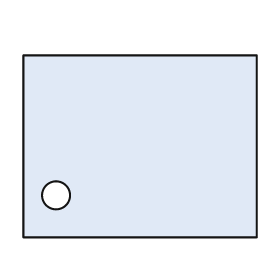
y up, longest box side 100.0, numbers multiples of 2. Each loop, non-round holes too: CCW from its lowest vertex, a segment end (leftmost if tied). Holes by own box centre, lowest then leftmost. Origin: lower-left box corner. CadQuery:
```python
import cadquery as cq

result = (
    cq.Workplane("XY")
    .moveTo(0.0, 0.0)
    .lineTo(100.0, 0.0)
    .lineTo(100.0, 78.0)
    .lineTo(0.0, 78.0)
    .close()
    .moveTo(14.0, 18.0)
    .circle(6.0)
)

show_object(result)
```